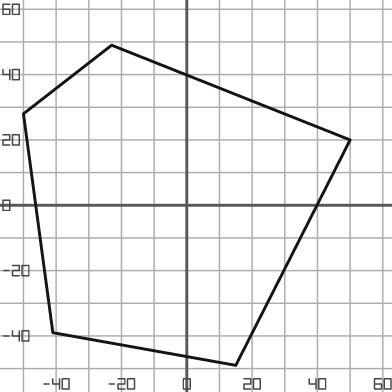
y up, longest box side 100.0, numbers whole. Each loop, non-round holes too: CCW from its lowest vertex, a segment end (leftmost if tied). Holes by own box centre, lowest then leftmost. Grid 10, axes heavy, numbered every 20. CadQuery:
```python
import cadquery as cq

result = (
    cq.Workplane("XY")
    .moveTo(15.0, -49.0)
    .lineTo(50.0, 20.0)
    .lineTo(-23.0, 49.0)
    .lineTo(-50.0, 28.0)
    .lineTo(-41.0, -39.0)
    .close()
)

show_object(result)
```